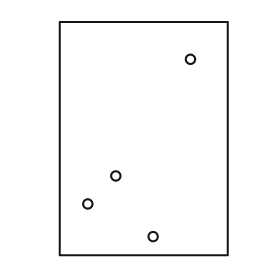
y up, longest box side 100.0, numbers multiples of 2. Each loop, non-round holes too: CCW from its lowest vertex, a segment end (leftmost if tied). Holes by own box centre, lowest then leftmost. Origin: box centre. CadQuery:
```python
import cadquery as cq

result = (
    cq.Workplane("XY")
    .moveTo(-36.0, -50.0)
    .lineTo(36.0, -50.0)
    .lineTo(36.0, 50.0)
    .lineTo(-36.0, 50.0)
    .close()
    .moveTo(4.0, -42.0)
    .circle(2.0)
    .moveTo(-24.0, -28.0)
    .circle(2.0)
    .moveTo(-12.0, -16.0)
    .circle(2.0)
    .moveTo(20.0, 34.0)
    .circle(2.0)
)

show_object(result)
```